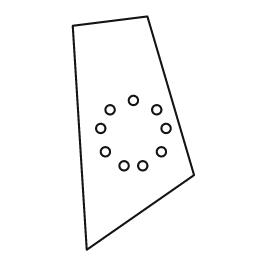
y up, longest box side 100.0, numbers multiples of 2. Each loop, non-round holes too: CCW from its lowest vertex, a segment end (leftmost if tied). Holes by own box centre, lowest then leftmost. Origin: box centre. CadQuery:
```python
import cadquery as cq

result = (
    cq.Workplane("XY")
    .moveTo(-20.0, -50.0)
    .lineTo(26.0, -18.0)
    .lineTo(6.0, 50.0)
    .lineTo(-26.0, 46.0)
    .close()
    .moveTo(-4.0, -14.0)
    .circle(2.0)
    .moveTo(4.0, -14.0)
    .circle(2.0)
    .moveTo(-12.0, -8.0)
    .circle(2.0)
    .moveTo(12.0, -8.0)
    .circle(2.0)
    .moveTo(-14.0, 2.0)
    .circle(2.0)
    .moveTo(14.0, 2.0)
    .circle(2.0)
    .moveTo(-10.0, 10.0)
    .circle(2.0)
    .moveTo(10.0, 10.0)
    .circle(2.0)
    .moveTo(0.0, 14.0)
    .circle(2.0)
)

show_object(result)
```